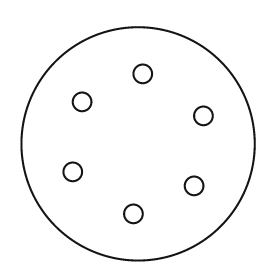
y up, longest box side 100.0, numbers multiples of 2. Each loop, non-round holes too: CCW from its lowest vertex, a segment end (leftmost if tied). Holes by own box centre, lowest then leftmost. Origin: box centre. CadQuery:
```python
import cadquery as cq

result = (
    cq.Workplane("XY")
    .moveTo(0.0, 0.0)
    .circle(50.0)
    .moveTo(-2.0, -30.0)
    .circle(4.0)
    .moveTo(24.0, -18.0)
    .circle(4.0)
    .moveTo(-28.0, -12.0)
    .circle(4.0)
    .moveTo(28.0, 12.0)
    .circle(4.0)
    .moveTo(-24.0, 18.0)
    .circle(4.0)
    .moveTo(2.0, 30.0)
    .circle(4.0)
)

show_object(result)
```